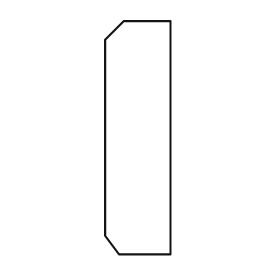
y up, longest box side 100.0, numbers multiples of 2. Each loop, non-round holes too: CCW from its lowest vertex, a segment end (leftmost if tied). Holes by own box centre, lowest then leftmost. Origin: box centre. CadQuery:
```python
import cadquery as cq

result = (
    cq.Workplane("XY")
    .moveTo(-8.0, -50.0)
    .lineTo(14.0, -50.0)
    .lineTo(14.0, 50.0)
    .lineTo(-6.0, 50.0)
    .lineTo(-14.0, 42.0)
    .lineTo(-14.0, -42.0)
    .close()
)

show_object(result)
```